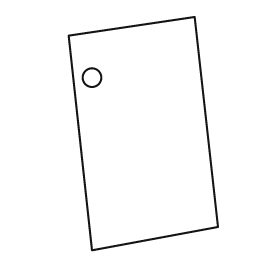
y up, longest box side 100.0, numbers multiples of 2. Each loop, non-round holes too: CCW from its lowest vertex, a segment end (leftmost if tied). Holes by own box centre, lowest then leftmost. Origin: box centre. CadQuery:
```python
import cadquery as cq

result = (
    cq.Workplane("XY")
    .moveTo(-22.0, -50.0)
    .lineTo(32.0, -40.0)
    .lineTo(22.0, 50.0)
    .lineTo(-32.0, 42.0)
    .close()
    .moveTo(-22.0, 24.0)
    .circle(4.0)
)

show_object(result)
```